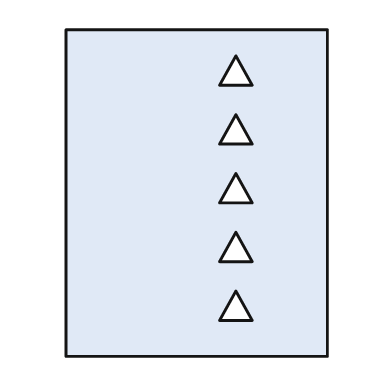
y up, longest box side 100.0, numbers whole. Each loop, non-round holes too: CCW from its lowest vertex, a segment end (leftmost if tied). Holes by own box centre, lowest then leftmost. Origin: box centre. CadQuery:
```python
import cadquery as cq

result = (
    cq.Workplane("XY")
    .moveTo(-40.0, -50.0)
    .lineTo(40.0, -50.0)
    .lineTo(40.0, 50.0)
    .lineTo(-40.0, 50.0)
    .close()
    .moveTo(7.0, -39.0)
    .lineTo(17.0, -39.0)
    .lineTo(12.0, -30.0)
    .close()
    .moveTo(7.0, -21.0)
    .lineTo(17.0, -21.0)
    .lineTo(12.0, -12.0)
    .close()
    .moveTo(7.0, -3.0)
    .lineTo(17.0, -3.0)
    .lineTo(12.0, 6.0)
    .close()
    .moveTo(7.0, 15.0)
    .lineTo(17.0, 15.0)
    .lineTo(12.0, 24.0)
    .close()
    .moveTo(7.0, 33.0)
    .lineTo(17.0, 33.0)
    .lineTo(12.0, 42.0)
    .close()
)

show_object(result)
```